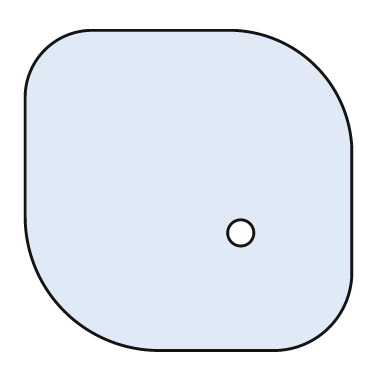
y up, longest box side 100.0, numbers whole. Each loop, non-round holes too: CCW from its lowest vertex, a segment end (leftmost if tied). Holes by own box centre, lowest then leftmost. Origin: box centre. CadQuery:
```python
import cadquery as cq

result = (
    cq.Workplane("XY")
    .moveTo(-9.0, -49.0)
    .lineTo(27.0, -49.0)
    .threePointArc((43.0, -42.0), (50.0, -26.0))
    .lineTo(50.0, 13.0)
    .threePointArc((39.0, 38.0), (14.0, 49.0))
    .lineTo(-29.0, 49.0)
    .threePointArc((-44.0, 43.0), (-50.0, 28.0))
    .lineTo(-50.0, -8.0)
    .threePointArc((-38.0, -37.0), (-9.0, -49.0))
    .close()
    .moveTo(16.0, -13.0)
    .circle(4.0)
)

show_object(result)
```